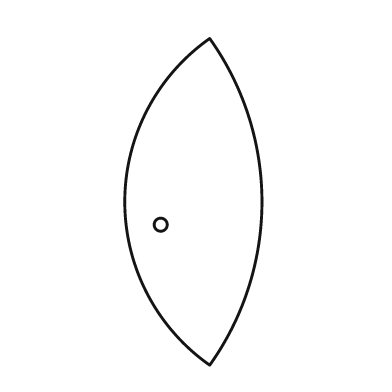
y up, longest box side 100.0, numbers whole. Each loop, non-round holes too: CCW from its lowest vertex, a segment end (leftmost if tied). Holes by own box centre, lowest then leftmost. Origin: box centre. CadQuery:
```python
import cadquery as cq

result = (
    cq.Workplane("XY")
    .moveTo(5.0, -50.0)
    .threePointArc((21.0, 0.0), (5.0, 50.0))
    .threePointArc((-21.0, 0.0), (5.0, -50.0))
    .close()
    .moveTo(-10.0, -7.0)
    .circle(2.0)
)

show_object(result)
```